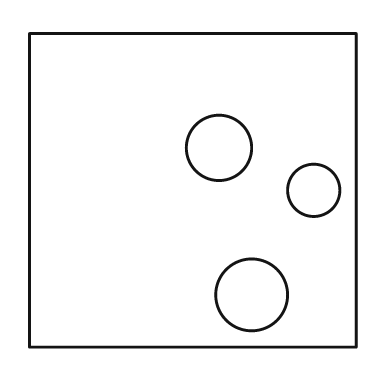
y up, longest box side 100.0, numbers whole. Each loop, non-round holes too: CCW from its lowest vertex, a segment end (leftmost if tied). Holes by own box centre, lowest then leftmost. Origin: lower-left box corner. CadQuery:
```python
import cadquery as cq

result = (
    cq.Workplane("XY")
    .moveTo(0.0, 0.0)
    .lineTo(100.0, 0.0)
    .lineTo(100.0, 96.0)
    .lineTo(0.0, 96.0)
    .close()
    .moveTo(68.0, 16.0)
    .circle(11.0)
    .moveTo(87.0, 48.0)
    .circle(8.0)
    .moveTo(58.0, 61.0)
    .circle(10.0)
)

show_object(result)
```